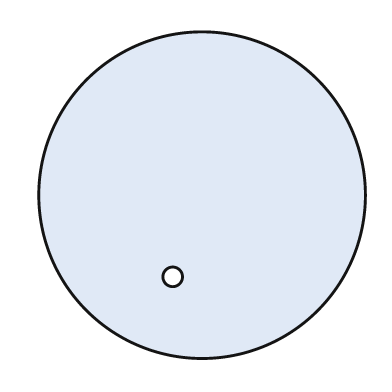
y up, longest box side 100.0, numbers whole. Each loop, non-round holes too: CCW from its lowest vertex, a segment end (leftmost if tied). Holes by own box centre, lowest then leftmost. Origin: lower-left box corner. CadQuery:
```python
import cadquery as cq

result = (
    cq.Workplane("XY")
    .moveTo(50.0, 50.0)
    .circle(50.0)
    .moveTo(41.0, 25.0)
    .circle(3.0)
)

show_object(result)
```